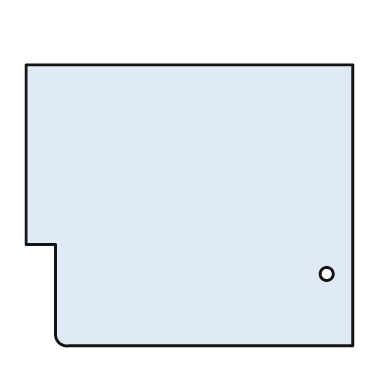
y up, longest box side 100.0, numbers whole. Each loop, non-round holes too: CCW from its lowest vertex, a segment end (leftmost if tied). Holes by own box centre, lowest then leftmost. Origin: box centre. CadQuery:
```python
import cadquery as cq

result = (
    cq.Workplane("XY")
    .moveTo(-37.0, -43.0)
    .lineTo(50.0, -43.0)
    .lineTo(50.0, 43.0)
    .lineTo(-50.0, 43.0)
    .lineTo(-50.0, -12.0)
    .lineTo(-41.0, -12.0)
    .lineTo(-41.0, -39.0)
    .threePointArc((-40.0, -42.0), (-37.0, -43.0))
    .close()
    .moveTo(42.0, -21.0)
    .circle(2.0)
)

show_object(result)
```